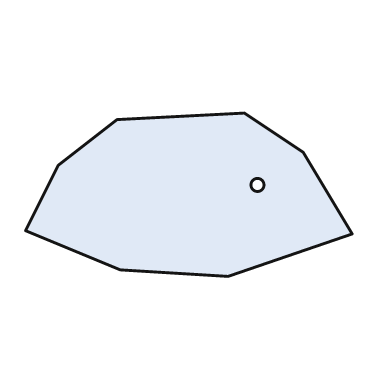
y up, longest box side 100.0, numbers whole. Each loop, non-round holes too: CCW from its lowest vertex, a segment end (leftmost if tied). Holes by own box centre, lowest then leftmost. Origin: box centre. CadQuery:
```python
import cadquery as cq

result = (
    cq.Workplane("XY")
    .moveTo(12.0, -25.0)
    .lineTo(50.0, -12.0)
    .lineTo(35.0, 13.0)
    .lineTo(17.0, 25.0)
    .lineTo(-22.0, 23.0)
    .lineTo(-40.0, 9.0)
    .lineTo(-50.0, -11.0)
    .lineTo(-21.0, -23.0)
    .close()
    .moveTo(21.0, 3.0)
    .circle(2.0)
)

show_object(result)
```